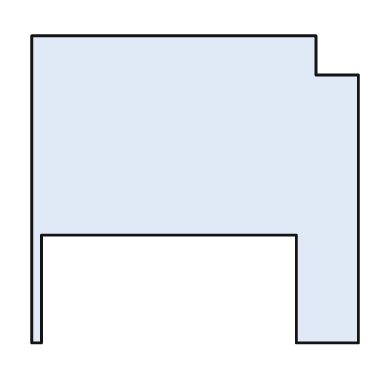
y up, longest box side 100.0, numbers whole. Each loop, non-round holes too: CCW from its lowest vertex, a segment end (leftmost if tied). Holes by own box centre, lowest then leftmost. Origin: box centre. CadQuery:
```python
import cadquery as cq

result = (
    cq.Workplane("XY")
    .moveTo(-50.0, -47.0)
    .lineTo(-47.0, -47.0)
    .lineTo(-47.0, -14.0)
    .lineTo(31.0, -14.0)
    .lineTo(31.0, -47.0)
    .lineTo(50.0, -47.0)
    .lineTo(50.0, 35.0)
    .lineTo(37.0, 35.0)
    .lineTo(37.0, 47.0)
    .lineTo(-50.0, 47.0)
    .close()
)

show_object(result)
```